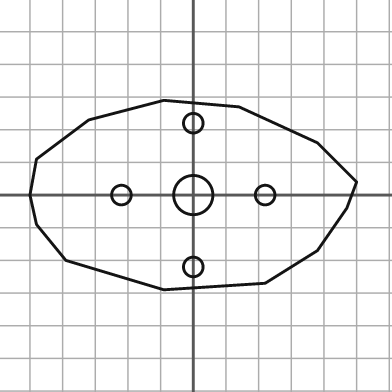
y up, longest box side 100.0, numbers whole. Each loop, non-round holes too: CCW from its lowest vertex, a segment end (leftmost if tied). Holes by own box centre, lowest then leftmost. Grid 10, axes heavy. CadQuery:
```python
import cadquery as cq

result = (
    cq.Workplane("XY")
    .moveTo(-9.0, -29.0)
    .lineTo(22.0, -27.0)
    .lineTo(38.0, -17.0)
    .lineTo(47.0, -4.0)
    .lineTo(50.0, 4.0)
    .lineTo(38.0, 16.0)
    .lineTo(14.0, 27.0)
    .lineTo(-9.0, 29.0)
    .lineTo(-32.0, 23.0)
    .lineTo(-48.0, 11.0)
    .lineTo(-50.0, 0.0)
    .lineTo(-48.0, -9.0)
    .lineTo(-39.0, -20.0)
    .close()
    .moveTo(0.0, -22.0)
    .circle(3.0)
    .moveTo(-22.0, 0.0)
    .circle(3.0)
    .moveTo(0.0, 0.0)
    .circle(6.0)
    .moveTo(22.0, 0.0)
    .circle(3.0)
    .moveTo(0.0, 22.0)
    .circle(3.0)
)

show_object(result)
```